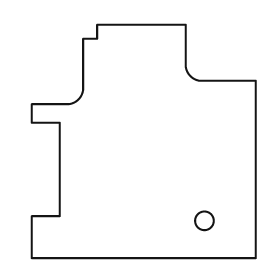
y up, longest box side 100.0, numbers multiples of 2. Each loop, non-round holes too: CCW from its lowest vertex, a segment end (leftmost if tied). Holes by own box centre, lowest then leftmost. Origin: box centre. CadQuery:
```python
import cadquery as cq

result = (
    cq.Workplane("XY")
    .moveTo(-48.0, -50.0)
    .lineTo(48.0, -50.0)
    .lineTo(48.0, 26.0)
    .lineTo(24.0, 26.0)
    .threePointArc((20.0, 28.0), (18.0, 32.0))
    .lineTo(18.0, 50.0)
    .lineTo(-20.0, 50.0)
    .lineTo(-20.0, 44.0)
    .lineTo(-26.0, 44.0)
    .lineTo(-26.0, 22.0)
    .threePointArc((-28.0, 18.0), (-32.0, 16.0))
    .lineTo(-48.0, 16.0)
    .lineTo(-48.0, 8.0)
    .lineTo(-36.0, 8.0)
    .lineTo(-36.0, -32.0)
    .lineTo(-48.0, -32.0)
    .close()
    .moveTo(26.0, -34.0)
    .circle(4.0)
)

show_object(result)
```